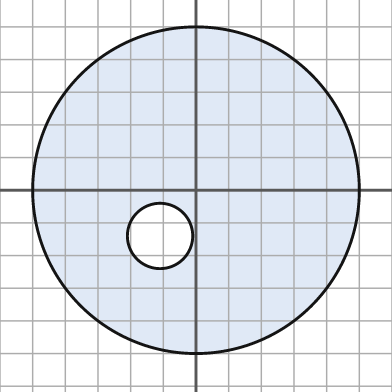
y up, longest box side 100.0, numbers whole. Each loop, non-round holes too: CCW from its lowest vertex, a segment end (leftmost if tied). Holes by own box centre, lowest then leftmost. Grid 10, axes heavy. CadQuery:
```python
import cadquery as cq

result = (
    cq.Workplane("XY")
    .moveTo(0.0, 0.0)
    .circle(50.0)
    .moveTo(-11.0, -14.0)
    .circle(10.0)
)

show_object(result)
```